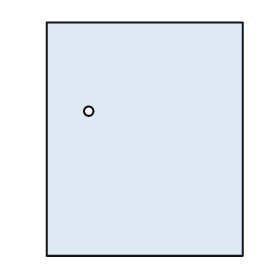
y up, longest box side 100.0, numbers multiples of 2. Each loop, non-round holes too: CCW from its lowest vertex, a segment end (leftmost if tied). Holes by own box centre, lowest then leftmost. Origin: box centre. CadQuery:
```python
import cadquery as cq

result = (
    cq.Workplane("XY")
    .moveTo(-42.0, -50.0)
    .lineTo(42.0, -50.0)
    .lineTo(42.0, 50.0)
    .lineTo(-42.0, 50.0)
    .close()
    .moveTo(-24.0, 12.0)
    .circle(2.0)
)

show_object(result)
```